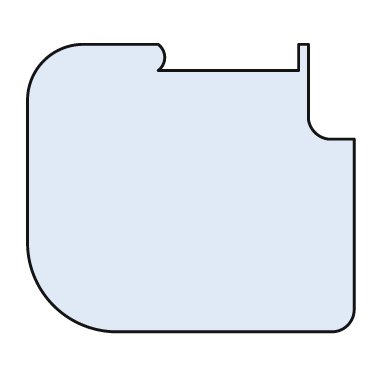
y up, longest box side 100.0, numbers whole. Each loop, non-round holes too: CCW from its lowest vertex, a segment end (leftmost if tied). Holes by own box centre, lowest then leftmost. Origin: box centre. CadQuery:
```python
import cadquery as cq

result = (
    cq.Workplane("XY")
    .moveTo(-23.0, -44.0)
    .lineTo(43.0, -44.0)
    .threePointArc((48.0, -42.0), (50.0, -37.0))
    .lineTo(50.0, 15.0)
    .lineTo(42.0, 15.0)
    .threePointArc((38.0, 17.0), (36.0, 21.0))
    .lineTo(36.0, 44.0)
    .lineTo(33.0, 44.0)
    .lineTo(33.0, 36.0)
    .lineTo(-10.0, 36.0)
    .threePointArc((-8.0, 40.0), (-10.0, 44.0))
    .lineTo(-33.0, 44.0)
    .threePointArc((-45.0, 39.0), (-50.0, 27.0))
    .lineTo(-50.0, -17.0)
    .threePointArc((-42.0, -36.0), (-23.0, -44.0))
    .close()
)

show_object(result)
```